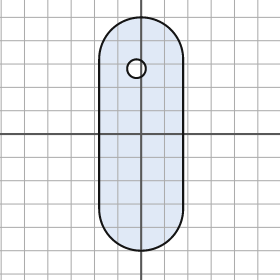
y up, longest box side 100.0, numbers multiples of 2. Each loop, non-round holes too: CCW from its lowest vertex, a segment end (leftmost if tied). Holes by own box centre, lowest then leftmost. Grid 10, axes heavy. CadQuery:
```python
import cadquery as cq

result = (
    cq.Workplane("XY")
    .moveTo(-18.0, -32.0)
    .threePointArc((0.0, -50.0), (18.0, -32.0))
    .lineTo(18.0, 32.0)
    .threePointArc((0.0, 50.0), (-18.0, 32.0))
    .close()
    .moveTo(-2.0, 28.0)
    .circle(4.0)
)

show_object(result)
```